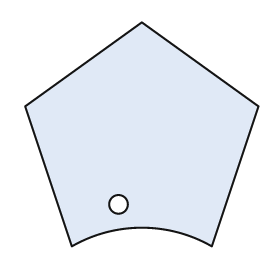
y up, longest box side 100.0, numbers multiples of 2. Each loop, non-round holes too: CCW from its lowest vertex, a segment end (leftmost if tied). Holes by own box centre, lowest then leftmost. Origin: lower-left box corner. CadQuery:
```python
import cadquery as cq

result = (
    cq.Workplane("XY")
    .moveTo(20.0, 0.0)
    .threePointArc((50.0, 8.0), (80.0, 0.0))
    .lineTo(100.0, 60.0)
    .lineTo(50.0, 96.0)
    .lineTo(0.0, 60.0)
    .close()
    .moveTo(40.0, 18.0)
    .circle(4.0)
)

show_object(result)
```